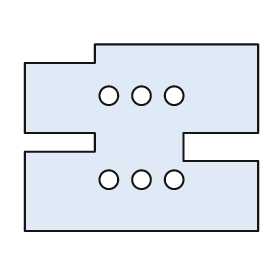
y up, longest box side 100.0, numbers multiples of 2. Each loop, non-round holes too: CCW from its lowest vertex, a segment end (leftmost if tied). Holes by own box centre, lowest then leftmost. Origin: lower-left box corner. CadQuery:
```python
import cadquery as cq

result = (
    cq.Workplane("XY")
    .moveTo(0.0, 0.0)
    .lineTo(100.0, 0.0)
    .lineTo(100.0, 30.0)
    .lineTo(68.0, 30.0)
    .lineTo(68.0, 42.0)
    .lineTo(100.0, 42.0)
    .lineTo(100.0, 80.0)
    .lineTo(30.0, 80.0)
    .lineTo(30.0, 72.0)
    .lineTo(0.0, 72.0)
    .lineTo(0.0, 42.0)
    .lineTo(30.0, 42.0)
    .lineTo(30.0, 34.0)
    .lineTo(0.0, 34.0)
    .close()
    .moveTo(36.0, 22.0)
    .circle(4.0)
    .moveTo(50.0, 22.0)
    .circle(4.0)
    .moveTo(64.0, 22.0)
    .circle(4.0)
    .moveTo(36.0, 58.0)
    .circle(4.0)
    .moveTo(50.0, 58.0)
    .circle(4.0)
    .moveTo(64.0, 58.0)
    .circle(4.0)
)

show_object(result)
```